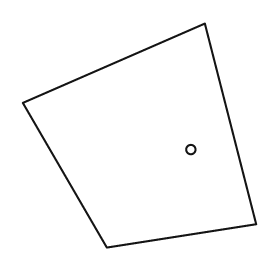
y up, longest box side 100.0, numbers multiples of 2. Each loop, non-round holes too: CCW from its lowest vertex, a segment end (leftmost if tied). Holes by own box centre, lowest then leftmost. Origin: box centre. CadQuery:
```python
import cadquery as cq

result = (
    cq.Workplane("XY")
    .moveTo(-14.0, -48.0)
    .lineTo(50.0, -38.0)
    .lineTo(28.0, 48.0)
    .lineTo(-50.0, 14.0)
    .close()
    .moveTo(22.0, -6.0)
    .circle(2.0)
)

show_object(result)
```